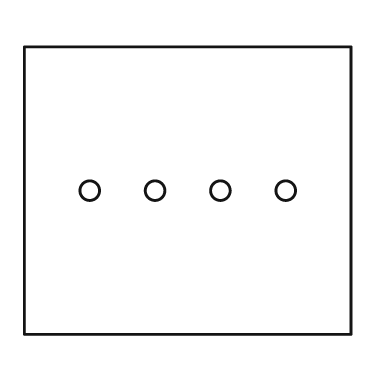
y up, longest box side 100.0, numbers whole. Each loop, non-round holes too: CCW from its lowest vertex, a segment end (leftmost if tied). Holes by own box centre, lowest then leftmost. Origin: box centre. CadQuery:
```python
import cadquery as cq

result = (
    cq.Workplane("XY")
    .moveTo(-50.0, -44.0)
    .lineTo(50.0, -44.0)
    .lineTo(50.0, 44.0)
    .lineTo(-50.0, 44.0)
    .close()
    .moveTo(-30.0, 0.0)
    .circle(3.0)
    .moveTo(-10.0, 0.0)
    .circle(3.0)
    .moveTo(10.0, 0.0)
    .circle(3.0)
    .moveTo(30.0, 0.0)
    .circle(3.0)
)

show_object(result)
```